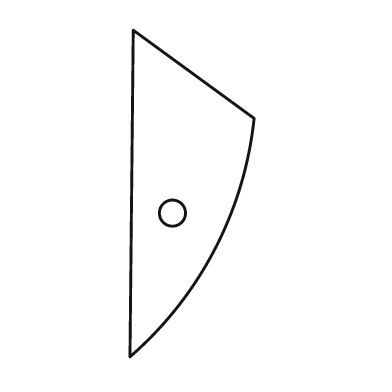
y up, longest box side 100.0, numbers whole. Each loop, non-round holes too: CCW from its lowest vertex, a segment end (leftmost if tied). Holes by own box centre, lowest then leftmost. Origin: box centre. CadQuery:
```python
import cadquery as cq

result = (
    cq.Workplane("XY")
    .moveTo(-19.0, -50.0)
    .threePointArc((7.0, -17.0), (19.0, 23.0))
    .lineTo(-18.0, 50.0)
    .close()
    .moveTo(-6.0, -6.0)
    .circle(4.0)
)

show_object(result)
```